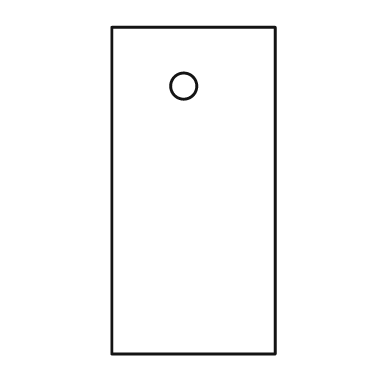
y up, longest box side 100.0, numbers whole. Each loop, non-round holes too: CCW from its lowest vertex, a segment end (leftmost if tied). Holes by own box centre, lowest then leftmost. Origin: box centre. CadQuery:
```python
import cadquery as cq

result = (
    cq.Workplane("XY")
    .moveTo(-25.0, -50.0)
    .lineTo(25.0, -50.0)
    .lineTo(25.0, 50.0)
    .lineTo(-25.0, 50.0)
    .close()
    .moveTo(-3.0, 32.0)
    .circle(4.0)
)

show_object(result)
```